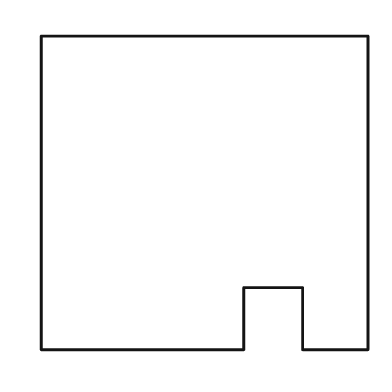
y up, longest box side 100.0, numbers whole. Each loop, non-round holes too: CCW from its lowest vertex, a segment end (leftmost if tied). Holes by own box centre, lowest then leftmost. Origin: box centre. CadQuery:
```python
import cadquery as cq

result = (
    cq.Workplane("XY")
    .moveTo(-50.0, -48.0)
    .lineTo(12.0, -48.0)
    .lineTo(12.0, -29.0)
    .lineTo(30.0, -29.0)
    .lineTo(30.0, -48.0)
    .lineTo(50.0, -48.0)
    .lineTo(50.0, 48.0)
    .lineTo(-50.0, 48.0)
    .close()
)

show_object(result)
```